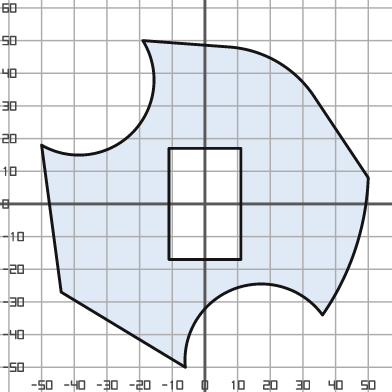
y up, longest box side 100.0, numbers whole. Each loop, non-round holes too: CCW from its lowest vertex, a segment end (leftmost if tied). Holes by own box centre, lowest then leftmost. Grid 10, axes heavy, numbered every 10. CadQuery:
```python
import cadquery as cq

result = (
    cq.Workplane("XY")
    .moveTo(-6.0, -50.0)
    .threePointArc((9.0, -26.0), (36.0, -34.0))
    .threePointArc((46.0, -14.0), (50.0, 8.0))
    .lineTo(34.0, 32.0)
    .threePointArc((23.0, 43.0), (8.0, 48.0))
    .lineTo(-19.0, 50.0)
    .threePointArc((-22.0, 22.0), (-50.0, 18.0))
    .lineTo(-44.0, -27.0)
    .close()
    .moveTo(-11.0, -17.0)
    .lineTo(11.0, -17.0)
    .lineTo(11.0, 17.0)
    .lineTo(-11.0, 17.0)
    .close()
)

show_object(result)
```